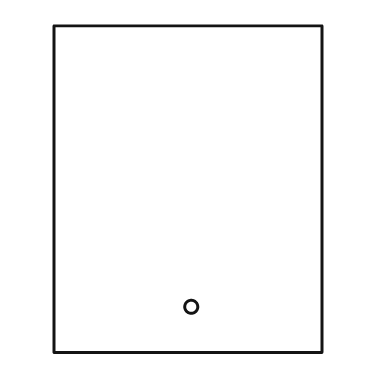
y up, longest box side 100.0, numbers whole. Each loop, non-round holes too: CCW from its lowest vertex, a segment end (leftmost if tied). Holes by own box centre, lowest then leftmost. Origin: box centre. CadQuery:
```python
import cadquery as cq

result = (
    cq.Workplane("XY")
    .moveTo(-41.0, -50.0)
    .lineTo(41.0, -50.0)
    .lineTo(41.0, 50.0)
    .lineTo(-41.0, 50.0)
    .close()
    .moveTo(1.0, -36.0)
    .circle(2.0)
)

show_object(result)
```